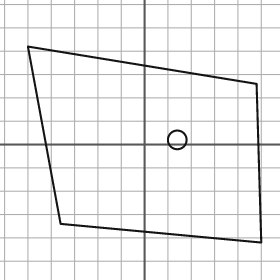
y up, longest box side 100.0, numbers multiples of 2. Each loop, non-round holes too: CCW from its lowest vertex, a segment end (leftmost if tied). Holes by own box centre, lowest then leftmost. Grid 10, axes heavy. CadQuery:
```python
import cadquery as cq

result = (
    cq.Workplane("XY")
    .moveTo(50.0, -42.0)
    .lineTo(48.0, 26.0)
    .lineTo(-50.0, 42.0)
    .lineTo(-36.0, -34.0)
    .close()
    .moveTo(14.0, 2.0)
    .circle(4.0)
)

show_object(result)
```